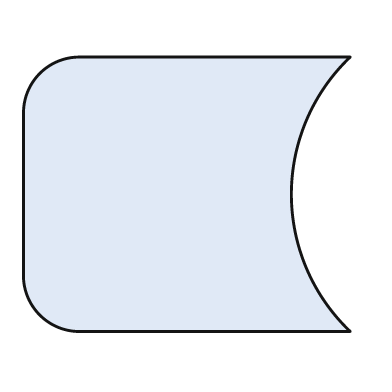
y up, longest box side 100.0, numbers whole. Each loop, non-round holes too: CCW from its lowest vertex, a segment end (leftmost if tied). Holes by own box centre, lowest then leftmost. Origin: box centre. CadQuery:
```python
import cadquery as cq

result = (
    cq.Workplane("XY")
    .moveTo(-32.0, -42.0)
    .lineTo(50.0, -42.0)
    .threePointArc((32.0, 0.0), (50.0, 42.0))
    .lineTo(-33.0, 42.0)
    .threePointArc((-45.0, 37.0), (-50.0, 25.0))
    .lineTo(-50.0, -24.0)
    .threePointArc((-45.0, -37.0), (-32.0, -42.0))
    .close()
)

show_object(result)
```